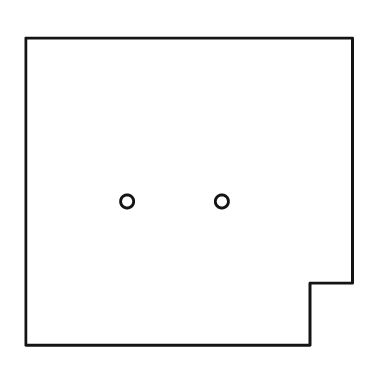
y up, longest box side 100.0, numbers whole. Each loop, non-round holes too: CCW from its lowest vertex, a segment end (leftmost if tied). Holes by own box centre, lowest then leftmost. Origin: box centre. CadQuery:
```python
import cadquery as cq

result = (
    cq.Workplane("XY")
    .moveTo(-50.0, -47.0)
    .lineTo(37.0, -47.0)
    .lineTo(37.0, -28.0)
    .lineTo(50.0, -28.0)
    .lineTo(50.0, 47.0)
    .lineTo(-50.0, 47.0)
    .close()
    .moveTo(-19.0, -3.0)
    .circle(2.0)
    .moveTo(10.0, -3.0)
    .circle(2.0)
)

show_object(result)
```